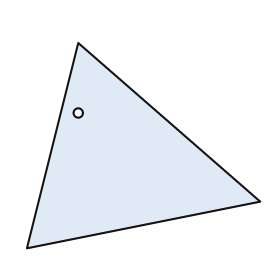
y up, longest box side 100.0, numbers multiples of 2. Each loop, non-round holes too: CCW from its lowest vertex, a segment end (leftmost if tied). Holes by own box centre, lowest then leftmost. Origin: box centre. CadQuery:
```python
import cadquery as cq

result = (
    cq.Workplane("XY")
    .moveTo(-50.0, -44.0)
    .lineTo(50.0, -24.0)
    .lineTo(-28.0, 44.0)
    .close()
    .moveTo(-28.0, 14.0)
    .circle(2.0)
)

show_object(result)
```